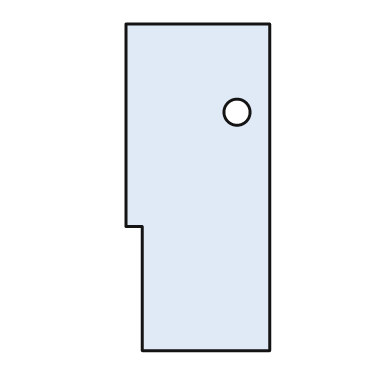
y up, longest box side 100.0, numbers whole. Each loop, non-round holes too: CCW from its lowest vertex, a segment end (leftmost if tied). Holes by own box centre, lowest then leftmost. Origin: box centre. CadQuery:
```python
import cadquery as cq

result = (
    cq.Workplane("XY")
    .moveTo(-17.0, -50.0)
    .lineTo(22.0, -50.0)
    .lineTo(22.0, 50.0)
    .lineTo(-22.0, 50.0)
    .lineTo(-22.0, -12.0)
    .lineTo(-17.0, -12.0)
    .close()
    .moveTo(12.0, 23.0)
    .circle(4.0)
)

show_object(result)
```